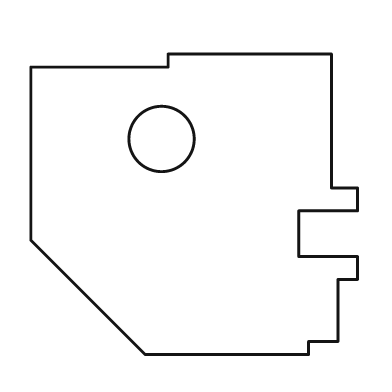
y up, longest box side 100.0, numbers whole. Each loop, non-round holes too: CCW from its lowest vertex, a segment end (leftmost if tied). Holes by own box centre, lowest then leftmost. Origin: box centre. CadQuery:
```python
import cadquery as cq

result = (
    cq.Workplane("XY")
    .moveTo(-15.0, -46.0)
    .lineTo(35.0, -46.0)
    .lineTo(35.0, -42.0)
    .lineTo(44.0, -42.0)
    .lineTo(44.0, -23.0)
    .lineTo(50.0, -23.0)
    .lineTo(50.0, -16.0)
    .lineTo(32.0, -16.0)
    .lineTo(32.0, -2.0)
    .lineTo(50.0, -2.0)
    .lineTo(50.0, 5.0)
    .lineTo(42.0, 5.0)
    .lineTo(42.0, 46.0)
    .lineTo(-8.0, 46.0)
    .lineTo(-8.0, 42.0)
    .lineTo(-50.0, 42.0)
    .lineTo(-50.0, -11.0)
    .close()
    .moveTo(-10.0, 20.0)
    .circle(10.0)
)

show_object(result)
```